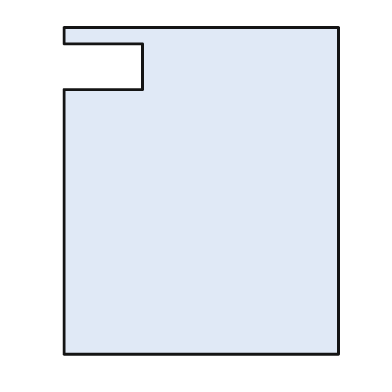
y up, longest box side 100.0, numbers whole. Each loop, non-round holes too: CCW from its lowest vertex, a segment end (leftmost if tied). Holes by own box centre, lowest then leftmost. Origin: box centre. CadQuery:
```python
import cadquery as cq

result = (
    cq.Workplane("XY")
    .moveTo(-42.0, -50.0)
    .lineTo(42.0, -50.0)
    .lineTo(42.0, 50.0)
    .lineTo(-42.0, 50.0)
    .lineTo(-42.0, 45.0)
    .lineTo(-18.0, 45.0)
    .lineTo(-18.0, 31.0)
    .lineTo(-42.0, 31.0)
    .close()
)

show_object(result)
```